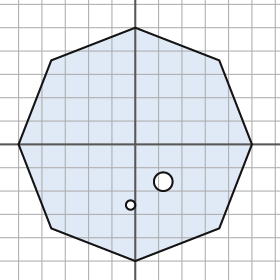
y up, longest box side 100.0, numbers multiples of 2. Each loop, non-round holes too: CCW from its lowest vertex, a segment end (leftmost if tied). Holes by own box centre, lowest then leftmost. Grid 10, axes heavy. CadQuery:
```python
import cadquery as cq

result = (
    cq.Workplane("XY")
    .moveTo(0.0, -50.0)
    .lineTo(36.0, -36.0)
    .lineTo(50.0, 0.0)
    .lineTo(36.0, 36.0)
    .lineTo(0.0, 50.0)
    .lineTo(-36.0, 36.0)
    .lineTo(-50.0, 0.0)
    .lineTo(-36.0, -36.0)
    .close()
    .moveTo(-2.0, -26.0)
    .circle(2.0)
    .moveTo(12.0, -16.0)
    .circle(4.0)
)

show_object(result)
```